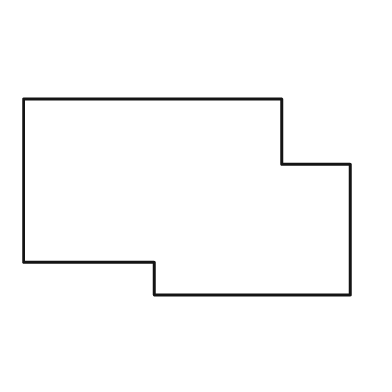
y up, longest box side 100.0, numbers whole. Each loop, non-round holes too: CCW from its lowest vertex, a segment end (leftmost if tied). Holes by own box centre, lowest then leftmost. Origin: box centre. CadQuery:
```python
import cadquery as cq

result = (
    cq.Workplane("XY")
    .moveTo(-10.0, -30.0)
    .lineTo(50.0, -30.0)
    .lineTo(50.0, 10.0)
    .lineTo(29.0, 10.0)
    .lineTo(29.0, 30.0)
    .lineTo(-50.0, 30.0)
    .lineTo(-50.0, -20.0)
    .lineTo(-10.0, -20.0)
    .close()
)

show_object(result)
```